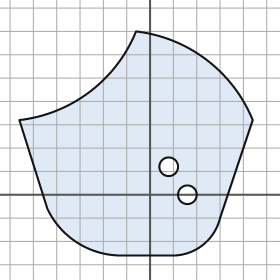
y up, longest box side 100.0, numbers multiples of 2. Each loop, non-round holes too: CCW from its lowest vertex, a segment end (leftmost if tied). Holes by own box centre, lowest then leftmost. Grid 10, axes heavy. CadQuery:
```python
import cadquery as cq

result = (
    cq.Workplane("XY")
    .moveTo(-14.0, -26.0)
    .lineTo(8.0, -26.0)
    .threePointArc((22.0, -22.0), (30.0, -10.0))
    .lineTo(44.0, 32.0)
    .threePointArc((24.0, 58.0), (-6.0, 70.0))
    .threePointArc((-26.0, 44.0), (-56.0, 32.0))
    .lineTo(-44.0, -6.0)
    .threePointArc((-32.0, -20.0), (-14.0, -26.0))
    .close()
    .moveTo(16.0, 0.0)
    .circle(4.0)
    .moveTo(8.0, 12.0)
    .circle(4.0)
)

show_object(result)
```